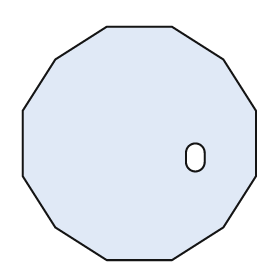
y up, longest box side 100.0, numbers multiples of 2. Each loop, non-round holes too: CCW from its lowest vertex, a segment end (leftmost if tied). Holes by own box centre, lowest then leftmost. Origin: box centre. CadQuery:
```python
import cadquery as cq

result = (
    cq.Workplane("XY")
    .moveTo(-14.0, -50.0)
    .lineTo(14.0, -50.0)
    .lineTo(36.0, -36.0)
    .lineTo(50.0, -14.0)
    .lineTo(50.0, 14.0)
    .lineTo(36.0, 36.0)
    .lineTo(14.0, 50.0)
    .lineTo(-14.0, 50.0)
    .lineTo(-36.0, 36.0)
    .lineTo(-50.0, 14.0)
    .lineTo(-50.0, -14.0)
    .lineTo(-36.0, -36.0)
    .close()
    .moveTo(20.0, -8.0)
    .threePointArc((24.0, -12.0), (28.0, -8.0))
    .lineTo(28.0, -4.0)
    .threePointArc((24.0, 0.0), (20.0, -4.0))
    .close()
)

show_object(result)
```